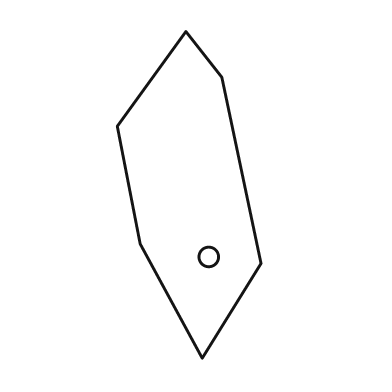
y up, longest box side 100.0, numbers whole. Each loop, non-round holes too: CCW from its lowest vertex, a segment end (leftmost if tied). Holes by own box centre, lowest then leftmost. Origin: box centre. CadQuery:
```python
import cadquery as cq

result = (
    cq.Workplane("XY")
    .moveTo(4.0, -50.0)
    .lineTo(22.0, -21.0)
    .lineTo(10.0, 36.0)
    .lineTo(-1.0, 50.0)
    .lineTo(-22.0, 21.0)
    .lineTo(-15.0, -15.0)
    .close()
    .moveTo(6.0, -19.0)
    .circle(3.0)
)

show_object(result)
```